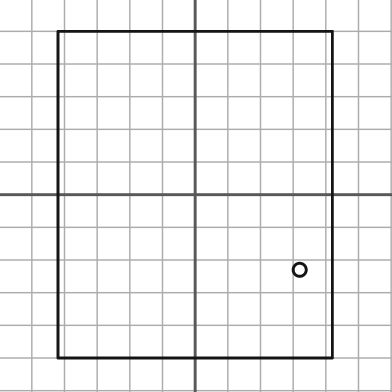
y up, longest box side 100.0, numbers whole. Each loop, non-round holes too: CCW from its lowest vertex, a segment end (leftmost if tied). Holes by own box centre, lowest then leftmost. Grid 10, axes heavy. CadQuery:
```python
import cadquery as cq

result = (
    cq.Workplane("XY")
    .moveTo(-42.0, -50.0)
    .lineTo(42.0, -50.0)
    .lineTo(42.0, 50.0)
    .lineTo(-42.0, 50.0)
    .close()
    .moveTo(32.0, -23.0)
    .circle(2.0)
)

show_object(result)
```